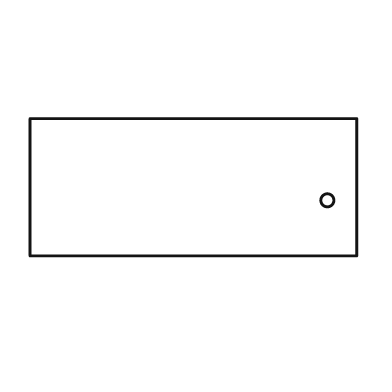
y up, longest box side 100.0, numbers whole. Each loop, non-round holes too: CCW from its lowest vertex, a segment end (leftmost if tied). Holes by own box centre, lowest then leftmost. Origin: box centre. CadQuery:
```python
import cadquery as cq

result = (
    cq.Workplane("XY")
    .moveTo(-50.0, -21.0)
    .lineTo(50.0, -21.0)
    .lineTo(50.0, 21.0)
    .lineTo(-50.0, 21.0)
    .close()
    .moveTo(41.0, -4.0)
    .circle(2.0)
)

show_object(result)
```